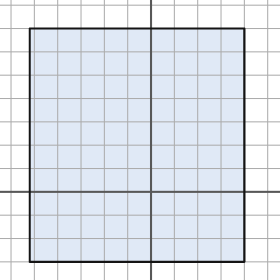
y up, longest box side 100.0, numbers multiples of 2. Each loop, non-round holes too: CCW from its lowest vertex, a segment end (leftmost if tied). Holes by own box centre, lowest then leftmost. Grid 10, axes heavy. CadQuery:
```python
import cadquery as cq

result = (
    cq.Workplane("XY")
    .moveTo(-52.0, -30.0)
    .lineTo(40.0, -30.0)
    .lineTo(40.0, 70.0)
    .lineTo(-52.0, 70.0)
    .close()
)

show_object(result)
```